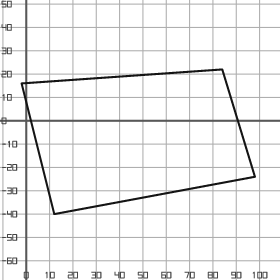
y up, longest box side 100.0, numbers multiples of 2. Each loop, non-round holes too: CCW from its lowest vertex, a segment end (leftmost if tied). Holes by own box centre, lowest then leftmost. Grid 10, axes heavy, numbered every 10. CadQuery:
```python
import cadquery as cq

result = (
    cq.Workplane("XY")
    .moveTo(12.0, -40.0)
    .lineTo(98.0, -24.0)
    .lineTo(84.0, 22.0)
    .lineTo(-2.0, 16.0)
    .close()
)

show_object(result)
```